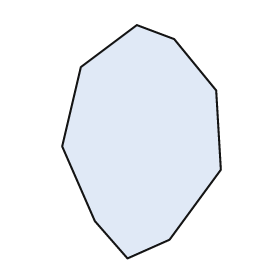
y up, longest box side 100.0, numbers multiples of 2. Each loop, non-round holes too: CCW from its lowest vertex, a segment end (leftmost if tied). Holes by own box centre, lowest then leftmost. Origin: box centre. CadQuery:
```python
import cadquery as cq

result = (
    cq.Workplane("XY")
    .moveTo(-6.0, -50.0)
    .lineTo(12.0, -42.0)
    .lineTo(34.0, -12.0)
    .lineTo(32.0, 22.0)
    .lineTo(14.0, 44.0)
    .lineTo(-2.0, 50.0)
    .lineTo(-26.0, 32.0)
    .lineTo(-34.0, -2.0)
    .lineTo(-20.0, -34.0)
    .close()
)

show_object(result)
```